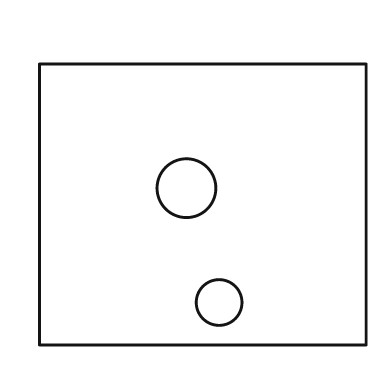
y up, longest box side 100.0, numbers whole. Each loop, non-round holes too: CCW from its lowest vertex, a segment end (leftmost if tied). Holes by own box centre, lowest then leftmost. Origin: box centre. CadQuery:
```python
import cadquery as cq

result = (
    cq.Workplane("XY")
    .moveTo(-50.0, -43.0)
    .lineTo(50.0, -43.0)
    .lineTo(50.0, 43.0)
    .lineTo(-50.0, 43.0)
    .close()
    .moveTo(5.0, -30.0)
    .circle(7.0)
    .moveTo(-5.0, 5.0)
    .circle(9.0)
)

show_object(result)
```